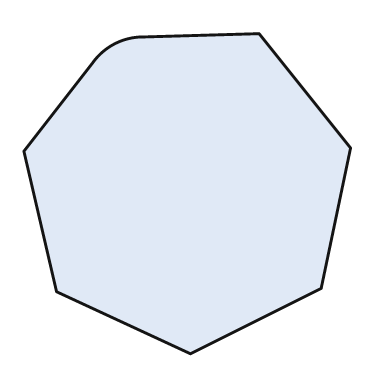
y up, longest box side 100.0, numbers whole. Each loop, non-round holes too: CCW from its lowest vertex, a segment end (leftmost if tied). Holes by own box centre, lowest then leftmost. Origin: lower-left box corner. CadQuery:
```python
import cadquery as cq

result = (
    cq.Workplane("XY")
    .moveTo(51.0, 0.0)
    .lineTo(91.0, 20.0)
    .lineTo(100.0, 63.0)
    .lineTo(72.0, 98.0)
    .lineTo(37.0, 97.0)
    .threePointArc((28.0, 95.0), (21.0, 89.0))
    .lineTo(0.0, 62.0)
    .lineTo(10.0, 19.0)
    .close()
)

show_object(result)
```